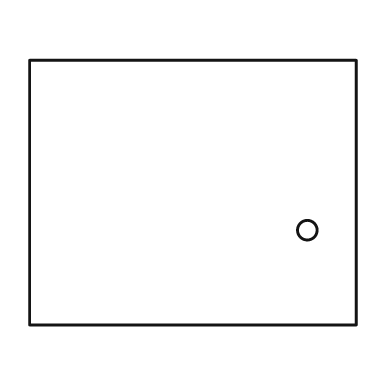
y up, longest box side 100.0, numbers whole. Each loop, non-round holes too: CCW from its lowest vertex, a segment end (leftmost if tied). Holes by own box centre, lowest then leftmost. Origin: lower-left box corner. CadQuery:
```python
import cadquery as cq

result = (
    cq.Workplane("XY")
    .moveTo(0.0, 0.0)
    .lineTo(100.0, 0.0)
    .lineTo(100.0, 81.0)
    .lineTo(0.0, 81.0)
    .close()
    .moveTo(85.0, 29.0)
    .circle(3.0)
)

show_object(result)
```